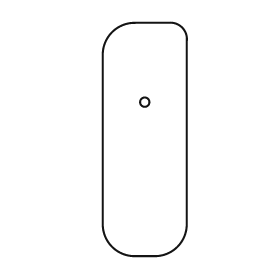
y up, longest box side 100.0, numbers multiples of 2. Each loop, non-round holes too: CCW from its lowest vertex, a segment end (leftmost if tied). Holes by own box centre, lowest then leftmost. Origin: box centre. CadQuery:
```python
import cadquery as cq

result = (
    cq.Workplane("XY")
    .moveTo(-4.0, -50.0)
    .lineTo(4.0, -50.0)
    .threePointArc((14.0, -46.0), (18.0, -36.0))
    .lineTo(18.0, 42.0)
    .threePointArc((16.0, 48.0), (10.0, 50.0))
    .lineTo(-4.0, 50.0)
    .threePointArc((-14.0, 46.0), (-18.0, 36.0))
    .lineTo(-18.0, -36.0)
    .threePointArc((-14.0, -46.0), (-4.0, -50.0))
    .close()
    .moveTo(0.0, 16.0)
    .circle(2.0)
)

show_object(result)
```